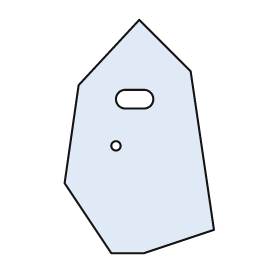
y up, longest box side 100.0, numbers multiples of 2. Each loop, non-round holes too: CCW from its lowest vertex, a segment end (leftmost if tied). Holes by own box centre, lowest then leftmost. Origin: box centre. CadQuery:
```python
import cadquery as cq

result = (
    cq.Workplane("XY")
    .moveTo(-12.0, -50.0)
    .lineTo(2.0, -50.0)
    .lineTo(32.0, -40.0)
    .lineTo(22.0, 28.0)
    .lineTo(0.0, 50.0)
    .lineTo(-26.0, 22.0)
    .lineTo(-32.0, -20.0)
    .close()
    .moveTo(-10.0, -4.0)
    .circle(2.0)
    .moveTo(-6.0, 12.0)
    .lineTo(2.0, 12.0)
    .threePointArc((6.0, 16.0), (2.0, 20.0))
    .lineTo(-6.0, 20.0)
    .threePointArc((-10.0, 16.0), (-6.0, 12.0))
    .close()
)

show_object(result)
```